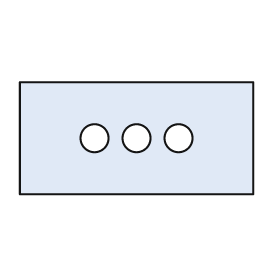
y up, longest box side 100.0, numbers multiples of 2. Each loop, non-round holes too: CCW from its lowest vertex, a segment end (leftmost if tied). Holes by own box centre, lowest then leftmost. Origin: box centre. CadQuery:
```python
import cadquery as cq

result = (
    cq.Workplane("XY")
    .moveTo(-50.0, -24.0)
    .lineTo(50.0, -24.0)
    .lineTo(50.0, 24.0)
    .lineTo(-50.0, 24.0)
    .close()
    .moveTo(-18.0, 0.0)
    .circle(6.0)
    .moveTo(0.0, 0.0)
    .circle(6.0)
    .moveTo(18.0, 0.0)
    .circle(6.0)
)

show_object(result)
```